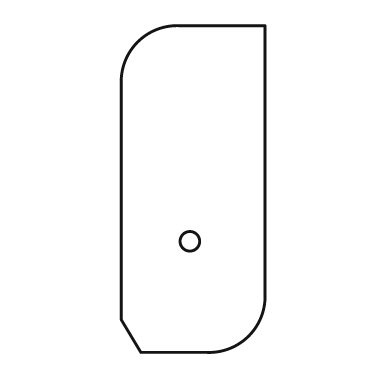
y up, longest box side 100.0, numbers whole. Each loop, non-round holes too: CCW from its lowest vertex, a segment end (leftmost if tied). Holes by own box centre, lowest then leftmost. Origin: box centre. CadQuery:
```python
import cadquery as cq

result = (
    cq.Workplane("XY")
    .moveTo(-16.0, -50.0)
    .lineTo(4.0, -50.0)
    .threePointArc((17.0, -45.0), (22.0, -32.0))
    .lineTo(22.0, 50.0)
    .lineTo(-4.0, 50.0)
    .threePointArc((-17.0, 45.0), (-22.0, 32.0))
    .lineTo(-22.0, -40.0)
    .close()
    .moveTo(-1.0, -16.0)
    .circle(3.0)
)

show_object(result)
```